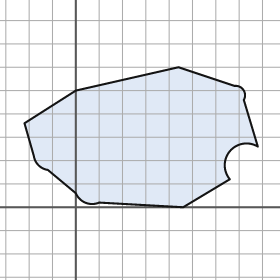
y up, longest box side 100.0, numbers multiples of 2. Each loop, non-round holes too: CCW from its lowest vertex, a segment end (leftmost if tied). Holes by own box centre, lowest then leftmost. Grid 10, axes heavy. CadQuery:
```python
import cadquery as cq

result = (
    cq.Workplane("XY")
    .moveTo(46.0, 0.0)
    .lineTo(66.0, 12.0)
    .threePointArc((66.0, 24.0), (78.0, 26.0))
    .lineTo(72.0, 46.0)
    .threePointArc((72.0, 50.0), (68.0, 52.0))
    .lineTo(44.0, 60.0)
    .lineTo(0.0, 50.0)
    .lineTo(-22.0, 36.0)
    .lineTo(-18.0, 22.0)
    .threePointArc((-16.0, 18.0), (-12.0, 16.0))
    .lineTo(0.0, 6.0)
    .threePointArc((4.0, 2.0), (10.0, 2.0))
    .close()
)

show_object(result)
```